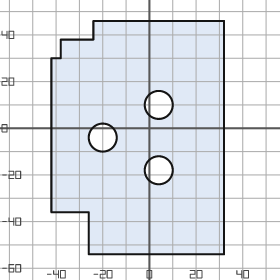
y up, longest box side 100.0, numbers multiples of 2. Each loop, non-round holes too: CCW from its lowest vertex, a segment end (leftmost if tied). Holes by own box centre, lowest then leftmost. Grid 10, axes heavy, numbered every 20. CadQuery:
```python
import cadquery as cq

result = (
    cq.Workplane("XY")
    .moveTo(-26.0, -54.0)
    .lineTo(32.0, -54.0)
    .lineTo(32.0, 46.0)
    .lineTo(-24.0, 46.0)
    .lineTo(-24.0, 38.0)
    .lineTo(-38.0, 38.0)
    .lineTo(-38.0, 30.0)
    .lineTo(-42.0, 30.0)
    .lineTo(-42.0, -36.0)
    .lineTo(-26.0, -36.0)
    .close()
    .moveTo(4.0, -18.0)
    .circle(6.0)
    .moveTo(-20.0, -4.0)
    .circle(6.0)
    .moveTo(4.0, 10.0)
    .circle(6.0)
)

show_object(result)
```